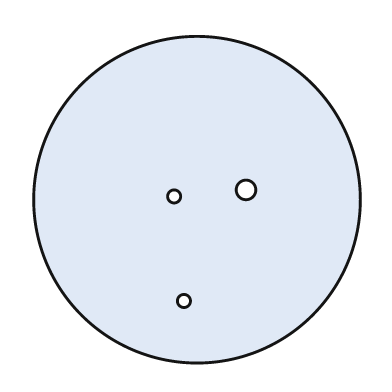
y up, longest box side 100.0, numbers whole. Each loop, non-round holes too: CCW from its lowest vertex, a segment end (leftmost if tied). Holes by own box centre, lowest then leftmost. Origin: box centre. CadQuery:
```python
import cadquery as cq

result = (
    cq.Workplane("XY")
    .moveTo(0.0, 0.0)
    .circle(50.0)
    .moveTo(-4.0, -31.0)
    .circle(2.0)
    .moveTo(-7.0, 1.0)
    .circle(2.0)
    .moveTo(15.0, 3.0)
    .circle(3.0)
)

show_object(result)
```